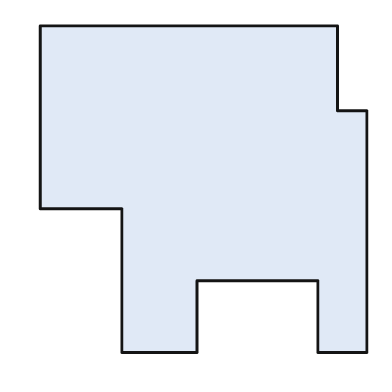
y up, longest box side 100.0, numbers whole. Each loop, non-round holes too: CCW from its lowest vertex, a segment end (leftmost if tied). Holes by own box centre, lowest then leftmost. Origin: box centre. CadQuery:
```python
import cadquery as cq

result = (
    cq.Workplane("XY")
    .moveTo(-25.0, -50.0)
    .lineTo(-2.0, -50.0)
    .lineTo(-2.0, -28.0)
    .lineTo(35.0, -28.0)
    .lineTo(35.0, -50.0)
    .lineTo(50.0, -50.0)
    .lineTo(50.0, 24.0)
    .lineTo(41.0, 24.0)
    .lineTo(41.0, 50.0)
    .lineTo(-50.0, 50.0)
    .lineTo(-50.0, -6.0)
    .lineTo(-25.0, -6.0)
    .close()
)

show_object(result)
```